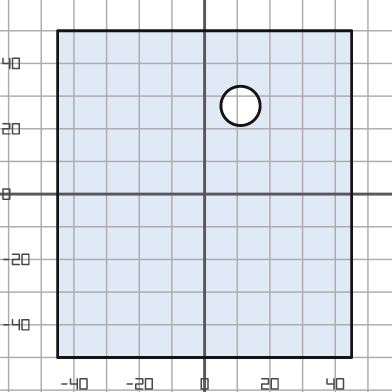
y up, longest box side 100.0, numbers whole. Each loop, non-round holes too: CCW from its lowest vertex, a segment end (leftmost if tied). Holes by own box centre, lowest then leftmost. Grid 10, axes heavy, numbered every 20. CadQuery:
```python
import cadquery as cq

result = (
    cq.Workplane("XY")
    .moveTo(-45.0, -50.0)
    .lineTo(45.0, -50.0)
    .lineTo(45.0, 50.0)
    .lineTo(-45.0, 50.0)
    .close()
    .moveTo(11.0, 27.0)
    .circle(6.0)
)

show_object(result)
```